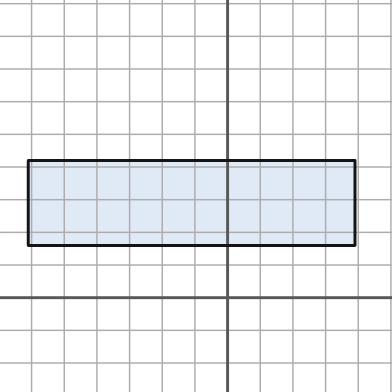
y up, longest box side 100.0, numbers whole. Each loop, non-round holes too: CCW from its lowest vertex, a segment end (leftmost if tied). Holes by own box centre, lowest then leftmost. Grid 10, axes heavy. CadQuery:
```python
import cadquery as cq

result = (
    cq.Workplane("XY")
    .moveTo(-61.0, 16.0)
    .lineTo(39.0, 16.0)
    .lineTo(39.0, 42.0)
    .lineTo(-61.0, 42.0)
    .close()
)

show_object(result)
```